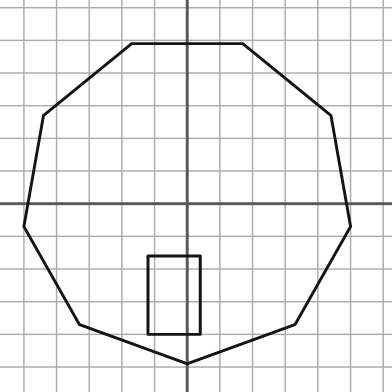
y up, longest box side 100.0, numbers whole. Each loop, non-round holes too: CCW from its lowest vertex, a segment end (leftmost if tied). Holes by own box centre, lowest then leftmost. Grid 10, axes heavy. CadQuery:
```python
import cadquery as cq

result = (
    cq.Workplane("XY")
    .moveTo(0.0, -49.0)
    .lineTo(33.0, -37.0)
    .lineTo(50.0, -7.0)
    .lineTo(44.0, 27.0)
    .lineTo(17.0, 49.0)
    .lineTo(-17.0, 49.0)
    .lineTo(-44.0, 27.0)
    .lineTo(-50.0, -7.0)
    .lineTo(-33.0, -37.0)
    .close()
    .moveTo(-12.0, -40.0)
    .lineTo(4.0, -40.0)
    .lineTo(4.0, -16.0)
    .lineTo(-12.0, -16.0)
    .close()
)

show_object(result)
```